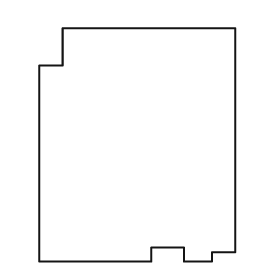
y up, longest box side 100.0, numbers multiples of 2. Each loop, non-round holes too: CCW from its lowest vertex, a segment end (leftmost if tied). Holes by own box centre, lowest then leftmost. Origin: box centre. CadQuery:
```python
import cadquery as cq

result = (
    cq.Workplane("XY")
    .moveTo(-42.0, -50.0)
    .lineTo(6.0, -50.0)
    .lineTo(6.0, -44.0)
    .lineTo(20.0, -44.0)
    .lineTo(20.0, -50.0)
    .lineTo(32.0, -50.0)
    .lineTo(32.0, -46.0)
    .lineTo(42.0, -46.0)
    .lineTo(42.0, 50.0)
    .lineTo(-32.0, 50.0)
    .lineTo(-32.0, 34.0)
    .lineTo(-42.0, 34.0)
    .close()
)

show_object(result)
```